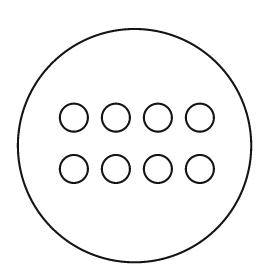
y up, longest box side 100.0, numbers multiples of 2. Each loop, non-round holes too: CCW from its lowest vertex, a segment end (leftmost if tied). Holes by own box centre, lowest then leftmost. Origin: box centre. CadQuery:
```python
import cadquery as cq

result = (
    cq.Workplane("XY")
    .moveTo(0.0, 0.0)
    .circle(50.0)
    .moveTo(-26.0, -10.0)
    .circle(6.0)
    .moveTo(-8.0, -10.0)
    .circle(6.0)
    .moveTo(10.0, -10.0)
    .circle(6.0)
    .moveTo(28.0, -10.0)
    .circle(6.0)
    .moveTo(-26.0, 12.0)
    .circle(6.0)
    .moveTo(-8.0, 12.0)
    .circle(6.0)
    .moveTo(10.0, 12.0)
    .circle(6.0)
    .moveTo(28.0, 12.0)
    .circle(6.0)
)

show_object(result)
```